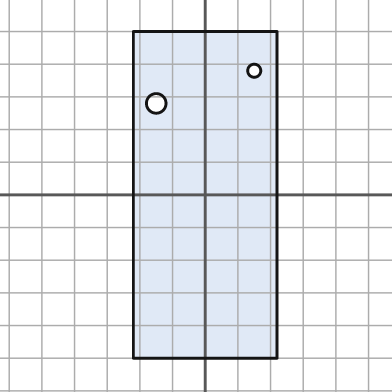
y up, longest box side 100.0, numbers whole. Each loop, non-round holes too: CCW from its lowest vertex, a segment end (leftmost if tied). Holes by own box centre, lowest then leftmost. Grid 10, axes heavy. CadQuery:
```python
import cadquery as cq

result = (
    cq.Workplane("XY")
    .moveTo(-22.0, -50.0)
    .lineTo(22.0, -50.0)
    .lineTo(22.0, 50.0)
    .lineTo(-22.0, 50.0)
    .close()
    .moveTo(-15.0, 28.0)
    .circle(3.0)
    .moveTo(15.0, 38.0)
    .circle(2.0)
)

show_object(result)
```